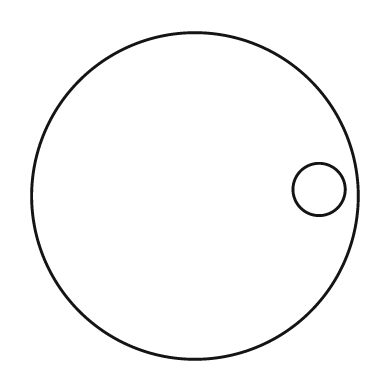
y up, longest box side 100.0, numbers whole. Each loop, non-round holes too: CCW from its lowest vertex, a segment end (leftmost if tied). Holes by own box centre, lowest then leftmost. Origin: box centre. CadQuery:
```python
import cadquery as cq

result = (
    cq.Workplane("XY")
    .moveTo(0.0, 0.0)
    .circle(50.0)
    .moveTo(38.0, 2.0)
    .circle(8.0)
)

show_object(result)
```